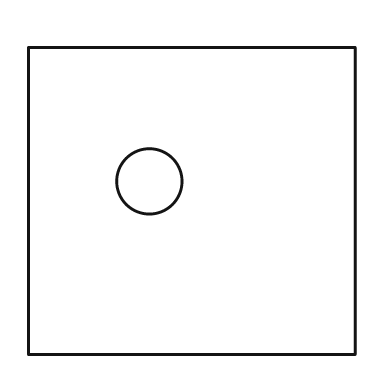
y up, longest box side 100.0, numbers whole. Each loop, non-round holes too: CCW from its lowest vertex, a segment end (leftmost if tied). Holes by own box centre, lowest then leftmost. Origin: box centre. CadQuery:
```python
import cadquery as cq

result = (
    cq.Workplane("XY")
    .moveTo(-50.0, -47.0)
    .lineTo(50.0, -47.0)
    .lineTo(50.0, 47.0)
    .lineTo(-50.0, 47.0)
    .close()
    .moveTo(-13.0, 6.0)
    .circle(10.0)
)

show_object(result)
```